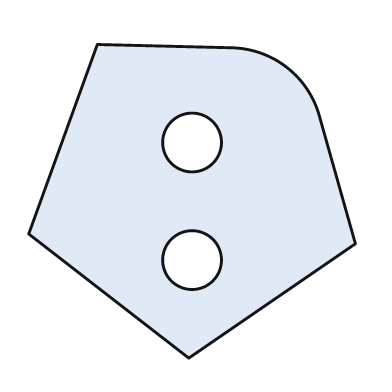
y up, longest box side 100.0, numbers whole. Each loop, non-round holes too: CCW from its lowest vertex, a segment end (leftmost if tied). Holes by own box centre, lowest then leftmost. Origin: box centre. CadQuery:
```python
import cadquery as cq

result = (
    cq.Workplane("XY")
    .moveTo(-1.0, -48.0)
    .lineTo(50.0, -13.0)
    .lineTo(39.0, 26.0)
    .threePointArc((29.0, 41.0), (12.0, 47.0))
    .lineTo(-29.0, 48.0)
    .lineTo(-50.0, -10.0)
    .close()
    .moveTo(0.0, -18.0)
    .circle(9.0)
    .moveTo(0.0, 18.0)
    .circle(9.0)
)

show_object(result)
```